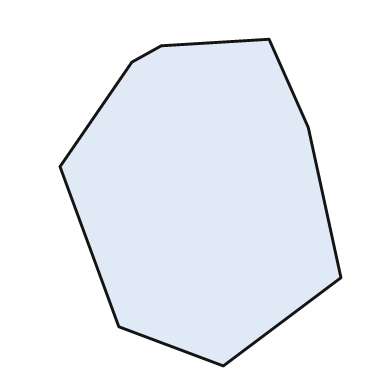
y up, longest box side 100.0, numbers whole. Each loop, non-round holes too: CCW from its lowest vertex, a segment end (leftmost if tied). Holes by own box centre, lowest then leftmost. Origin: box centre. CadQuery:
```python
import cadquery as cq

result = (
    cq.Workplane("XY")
    .moveTo(7.0, -50.0)
    .lineTo(43.0, -23.0)
    .lineTo(33.0, 23.0)
    .lineTo(21.0, 50.0)
    .lineTo(-12.0, 48.0)
    .lineTo(-21.0, 43.0)
    .lineTo(-43.0, 11.0)
    .lineTo(-25.0, -38.0)
    .close()
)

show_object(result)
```